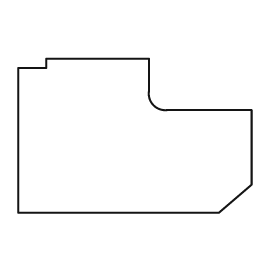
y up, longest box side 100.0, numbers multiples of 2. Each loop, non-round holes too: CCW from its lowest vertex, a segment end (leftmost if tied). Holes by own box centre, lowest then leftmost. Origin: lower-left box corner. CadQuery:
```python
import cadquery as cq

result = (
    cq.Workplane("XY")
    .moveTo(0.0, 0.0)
    .lineTo(86.0, 0.0)
    .lineTo(100.0, 12.0)
    .lineTo(100.0, 44.0)
    .lineTo(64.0, 44.0)
    .threePointArc((58.0, 46.0), (56.0, 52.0))
    .lineTo(56.0, 66.0)
    .lineTo(12.0, 66.0)
    .lineTo(12.0, 62.0)
    .lineTo(0.0, 62.0)
    .close()
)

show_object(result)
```